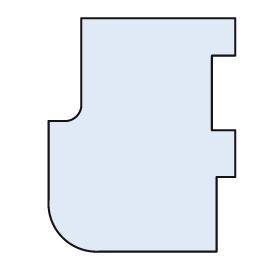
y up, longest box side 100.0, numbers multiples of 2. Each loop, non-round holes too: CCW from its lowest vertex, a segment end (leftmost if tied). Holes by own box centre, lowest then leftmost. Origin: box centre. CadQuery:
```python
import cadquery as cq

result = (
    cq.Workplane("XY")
    .moveTo(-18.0, -50.0)
    .lineTo(32.0, -50.0)
    .lineTo(32.0, -18.0)
    .lineTo(40.0, -18.0)
    .lineTo(40.0, 2.0)
    .lineTo(30.0, 2.0)
    .lineTo(30.0, 34.0)
    .lineTo(40.0, 34.0)
    .lineTo(40.0, 50.0)
    .lineTo(-26.0, 50.0)
    .lineTo(-26.0, 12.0)
    .threePointArc((-28.0, 8.0), (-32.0, 6.0))
    .lineTo(-40.0, 6.0)
    .lineTo(-40.0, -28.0)
    .threePointArc((-34.0, -44.0), (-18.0, -50.0))
    .close()
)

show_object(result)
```